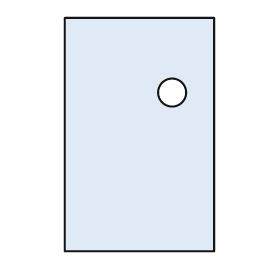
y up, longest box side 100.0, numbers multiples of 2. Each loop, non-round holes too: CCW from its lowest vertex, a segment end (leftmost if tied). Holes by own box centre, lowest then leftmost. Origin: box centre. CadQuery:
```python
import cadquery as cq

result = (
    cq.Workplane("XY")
    .moveTo(-32.0, -50.0)
    .lineTo(32.0, -50.0)
    .lineTo(32.0, 50.0)
    .lineTo(-32.0, 50.0)
    .close()
    .moveTo(14.0, 18.0)
    .circle(6.0)
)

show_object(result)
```